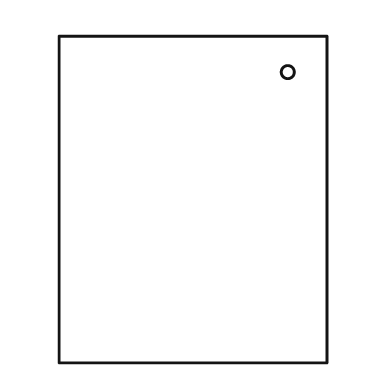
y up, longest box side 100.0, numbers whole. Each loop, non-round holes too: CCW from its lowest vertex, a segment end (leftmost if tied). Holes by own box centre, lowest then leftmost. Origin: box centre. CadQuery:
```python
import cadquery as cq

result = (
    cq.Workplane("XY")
    .moveTo(-41.0, -50.0)
    .lineTo(41.0, -50.0)
    .lineTo(41.0, 50.0)
    .lineTo(-41.0, 50.0)
    .close()
    .moveTo(29.0, 39.0)
    .circle(2.0)
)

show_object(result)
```